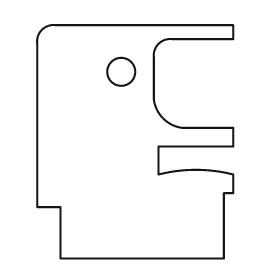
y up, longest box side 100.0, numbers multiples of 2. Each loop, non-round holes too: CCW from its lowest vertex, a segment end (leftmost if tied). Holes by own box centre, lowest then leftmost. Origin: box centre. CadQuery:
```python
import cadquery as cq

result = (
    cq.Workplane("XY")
    .moveTo(-32.0, -50.0)
    .lineTo(38.0, -50.0)
    .lineTo(38.0, -22.0)
    .lineTo(42.0, -22.0)
    .lineTo(42.0, -14.0)
    .threePointArc((26.0, -12.0), (10.0, -14.0))
    .lineTo(10.0, -2.0)
    .lineTo(42.0, -2.0)
    .lineTo(42.0, 6.0)
    .lineTo(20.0, 6.0)
    .threePointArc((12.0, 10.0), (8.0, 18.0))
    .lineTo(8.0, 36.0)
    .threePointArc((10.0, 42.0), (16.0, 44.0))
    .lineTo(42.0, 44.0)
    .lineTo(42.0, 50.0)
    .lineTo(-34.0, 50.0)
    .threePointArc((-40.0, 48.0), (-42.0, 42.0))
    .lineTo(-42.0, -28.0)
    .lineTo(-32.0, -28.0)
    .close()
    .moveTo(-6.0, 30.0)
    .circle(6.0)
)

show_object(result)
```